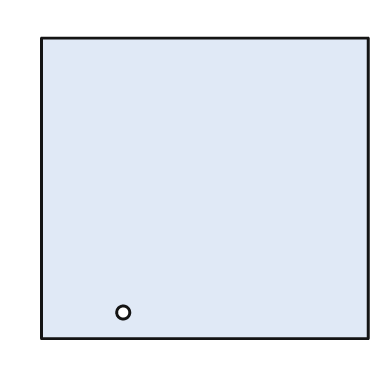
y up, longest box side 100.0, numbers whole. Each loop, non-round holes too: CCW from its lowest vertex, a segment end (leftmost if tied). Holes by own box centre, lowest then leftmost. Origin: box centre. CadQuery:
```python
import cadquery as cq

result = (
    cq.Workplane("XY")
    .moveTo(-50.0, -46.0)
    .lineTo(50.0, -46.0)
    .lineTo(50.0, 46.0)
    .lineTo(-50.0, 46.0)
    .close()
    .moveTo(-25.0, -38.0)
    .circle(2.0)
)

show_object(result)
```